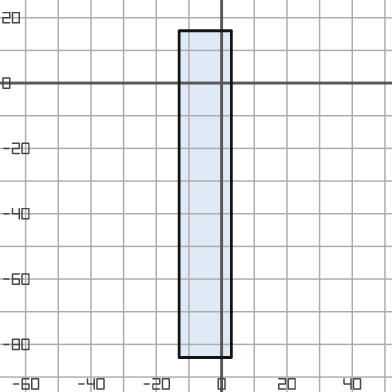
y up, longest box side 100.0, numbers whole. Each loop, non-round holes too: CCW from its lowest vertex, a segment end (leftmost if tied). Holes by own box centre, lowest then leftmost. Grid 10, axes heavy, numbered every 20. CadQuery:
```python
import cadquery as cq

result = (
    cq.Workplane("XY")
    .moveTo(-13.0, -84.0)
    .lineTo(3.0, -84.0)
    .lineTo(3.0, 16.0)
    .lineTo(-13.0, 16.0)
    .close()
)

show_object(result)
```